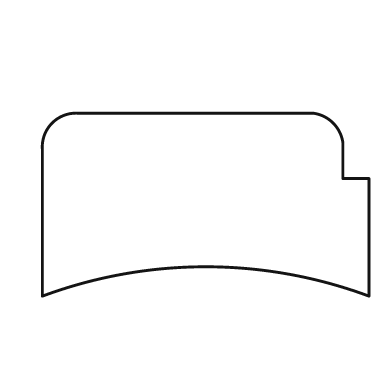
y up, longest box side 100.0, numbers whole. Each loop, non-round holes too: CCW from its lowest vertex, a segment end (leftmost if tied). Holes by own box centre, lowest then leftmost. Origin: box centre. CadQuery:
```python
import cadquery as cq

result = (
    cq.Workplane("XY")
    .moveTo(-50.0, -28.0)
    .threePointArc((0.0, -19.0), (50.0, -28.0))
    .lineTo(50.0, 8.0)
    .lineTo(42.0, 8.0)
    .lineTo(42.0, 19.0)
    .threePointArc((39.0, 25.0), (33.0, 28.0))
    .lineTo(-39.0, 28.0)
    .threePointArc((-47.0, 25.0), (-50.0, 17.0))
    .close()
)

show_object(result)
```